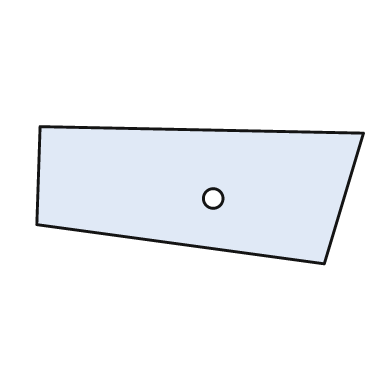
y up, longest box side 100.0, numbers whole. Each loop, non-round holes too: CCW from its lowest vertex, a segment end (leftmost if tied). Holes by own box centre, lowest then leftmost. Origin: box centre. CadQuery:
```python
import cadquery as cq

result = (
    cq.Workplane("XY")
    .moveTo(38.0, -21.0)
    .lineTo(50.0, 19.0)
    .lineTo(-49.0, 21.0)
    .lineTo(-50.0, -9.0)
    .close()
    .moveTo(4.0, -1.0)
    .circle(3.0)
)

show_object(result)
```